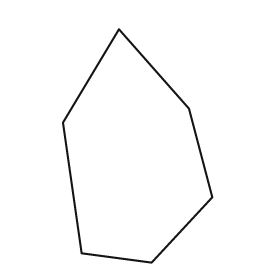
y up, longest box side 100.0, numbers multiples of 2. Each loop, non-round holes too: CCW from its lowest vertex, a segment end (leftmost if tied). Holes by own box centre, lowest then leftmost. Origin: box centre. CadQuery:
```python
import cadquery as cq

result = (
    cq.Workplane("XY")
    .moveTo(6.0, -50.0)
    .lineTo(32.0, -22.0)
    .lineTo(22.0, 16.0)
    .lineTo(-8.0, 50.0)
    .lineTo(-32.0, 10.0)
    .lineTo(-24.0, -46.0)
    .close()
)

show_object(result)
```